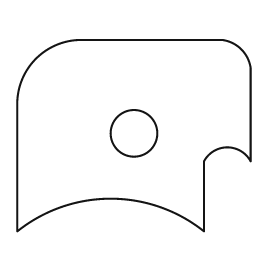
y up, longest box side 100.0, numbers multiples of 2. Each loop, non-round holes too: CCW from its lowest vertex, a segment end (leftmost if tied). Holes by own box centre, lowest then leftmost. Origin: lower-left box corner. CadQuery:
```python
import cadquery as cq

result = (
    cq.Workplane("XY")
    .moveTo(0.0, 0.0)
    .threePointArc((40.0, 14.0), (80.0, 0.0))
    .lineTo(80.0, 30.0)
    .threePointArc((90.0, 36.0), (100.0, 30.0))
    .lineTo(100.0, 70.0)
    .threePointArc((96.0, 78.0), (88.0, 82.0))
    .lineTo(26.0, 82.0)
    .threePointArc((8.0, 74.0), (0.0, 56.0))
    .close()
    .moveTo(50.0, 42.0)
    .circle(10.0)
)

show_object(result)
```